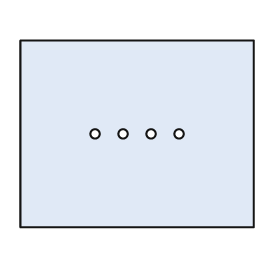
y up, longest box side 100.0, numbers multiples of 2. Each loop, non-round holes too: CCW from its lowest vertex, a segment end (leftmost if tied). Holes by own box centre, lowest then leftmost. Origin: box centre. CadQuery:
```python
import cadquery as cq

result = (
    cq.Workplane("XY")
    .moveTo(-50.0, -40.0)
    .lineTo(50.0, -40.0)
    .lineTo(50.0, 40.0)
    .lineTo(-50.0, 40.0)
    .close()
    .moveTo(-18.0, 0.0)
    .circle(2.0)
    .moveTo(-6.0, 0.0)
    .circle(2.0)
    .moveTo(6.0, 0.0)
    .circle(2.0)
    .moveTo(18.0, 0.0)
    .circle(2.0)
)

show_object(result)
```